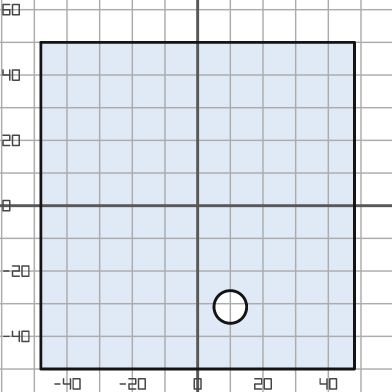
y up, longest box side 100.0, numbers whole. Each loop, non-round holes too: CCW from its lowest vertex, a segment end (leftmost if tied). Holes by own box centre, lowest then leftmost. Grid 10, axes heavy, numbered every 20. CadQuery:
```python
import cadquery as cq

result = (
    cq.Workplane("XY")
    .moveTo(-48.0, -50.0)
    .lineTo(48.0, -50.0)
    .lineTo(48.0, 50.0)
    .lineTo(-48.0, 50.0)
    .close()
    .moveTo(10.0, -31.0)
    .circle(5.0)
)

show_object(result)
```